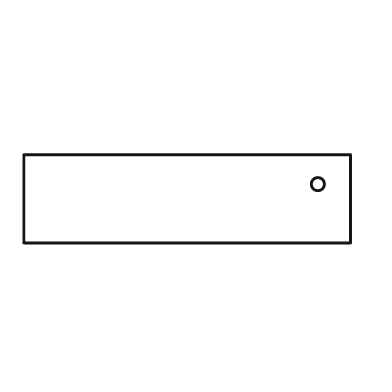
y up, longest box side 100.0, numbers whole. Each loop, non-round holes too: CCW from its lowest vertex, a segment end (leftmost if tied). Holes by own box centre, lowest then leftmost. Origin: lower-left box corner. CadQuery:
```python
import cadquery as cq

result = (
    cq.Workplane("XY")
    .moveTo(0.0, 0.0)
    .lineTo(100.0, 0.0)
    .lineTo(100.0, 27.0)
    .lineTo(0.0, 27.0)
    .close()
    .moveTo(90.0, 18.0)
    .circle(2.0)
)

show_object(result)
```